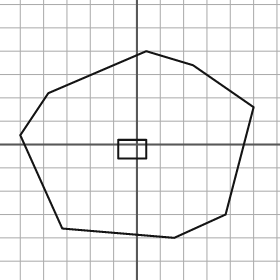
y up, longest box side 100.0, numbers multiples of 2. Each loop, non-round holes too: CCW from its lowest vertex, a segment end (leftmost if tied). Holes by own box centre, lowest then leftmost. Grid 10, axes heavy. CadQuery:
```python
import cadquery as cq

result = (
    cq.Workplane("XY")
    .moveTo(16.0, -40.0)
    .lineTo(38.0, -30.0)
    .lineTo(50.0, 16.0)
    .lineTo(24.0, 34.0)
    .lineTo(4.0, 40.0)
    .lineTo(-38.0, 22.0)
    .lineTo(-50.0, 4.0)
    .lineTo(-32.0, -36.0)
    .close()
    .moveTo(-8.0, -6.0)
    .lineTo(4.0, -6.0)
    .lineTo(4.0, 2.0)
    .lineTo(-8.0, 2.0)
    .close()
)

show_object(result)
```